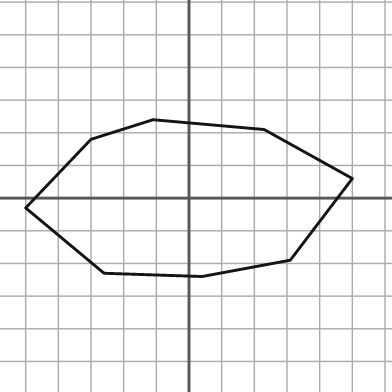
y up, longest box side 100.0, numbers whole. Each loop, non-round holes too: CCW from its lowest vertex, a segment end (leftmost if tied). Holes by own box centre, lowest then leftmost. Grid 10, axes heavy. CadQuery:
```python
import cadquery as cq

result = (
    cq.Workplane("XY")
    .moveTo(4.0, -24.0)
    .lineTo(31.0, -19.0)
    .lineTo(50.0, 6.0)
    .lineTo(23.0, 21.0)
    .lineTo(-11.0, 24.0)
    .lineTo(-30.0, 18.0)
    .lineTo(-50.0, -3.0)
    .lineTo(-26.0, -23.0)
    .close()
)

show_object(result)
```